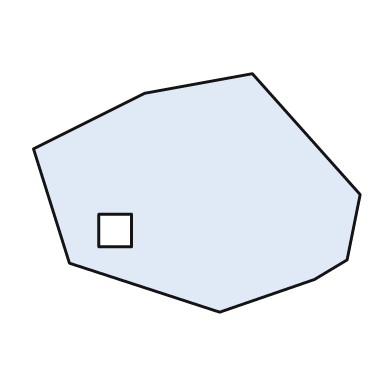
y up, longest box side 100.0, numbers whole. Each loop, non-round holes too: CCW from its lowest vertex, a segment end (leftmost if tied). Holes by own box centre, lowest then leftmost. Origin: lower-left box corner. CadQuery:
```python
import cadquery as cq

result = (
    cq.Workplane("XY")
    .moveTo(57.0, 0.0)
    .lineTo(86.0, 10.0)
    .lineTo(96.0, 16.0)
    .lineTo(100.0, 36.0)
    .lineTo(67.0, 73.0)
    .lineTo(34.0, 67.0)
    .lineTo(0.0, 50.0)
    .lineTo(11.0, 15.0)
    .close()
    .moveTo(20.0, 20.0)
    .lineTo(30.0, 20.0)
    .lineTo(30.0, 30.0)
    .lineTo(20.0, 30.0)
    .close()
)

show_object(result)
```